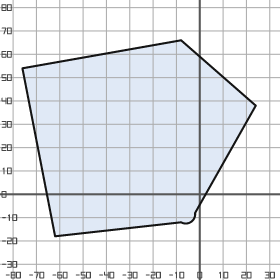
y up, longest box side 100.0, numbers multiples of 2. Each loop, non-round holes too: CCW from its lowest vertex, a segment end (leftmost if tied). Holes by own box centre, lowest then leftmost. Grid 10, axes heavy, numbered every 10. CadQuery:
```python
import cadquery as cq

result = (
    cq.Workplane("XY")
    .moveTo(-62.0, -18.0)
    .lineTo(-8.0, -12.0)
    .threePointArc((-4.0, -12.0), (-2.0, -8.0))
    .lineTo(24.0, 38.0)
    .lineTo(-8.0, 66.0)
    .lineTo(-76.0, 54.0)
    .close()
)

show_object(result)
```